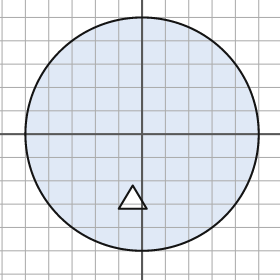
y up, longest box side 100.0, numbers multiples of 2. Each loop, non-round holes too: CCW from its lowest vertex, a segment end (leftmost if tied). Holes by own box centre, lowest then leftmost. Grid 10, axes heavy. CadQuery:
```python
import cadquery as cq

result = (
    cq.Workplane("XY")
    .moveTo(0.0, 0.0)
    .circle(50.0)
    .moveTo(-10.0, -32.0)
    .lineTo(2.0, -32.0)
    .lineTo(-4.0, -22.0)
    .close()
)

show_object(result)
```